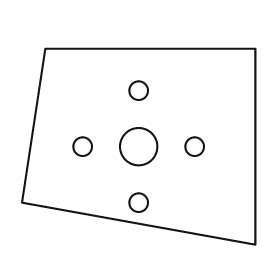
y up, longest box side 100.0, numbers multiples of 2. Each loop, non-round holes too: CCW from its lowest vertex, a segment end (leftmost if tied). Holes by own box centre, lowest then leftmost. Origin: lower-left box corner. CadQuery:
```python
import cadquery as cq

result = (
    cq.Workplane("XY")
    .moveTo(100.0, 0.0)
    .lineTo(100.0, 84.0)
    .lineTo(10.0, 84.0)
    .lineTo(0.0, 18.0)
    .close()
    .moveTo(50.0, 18.0)
    .circle(4.0)
    .moveTo(26.0, 42.0)
    .circle(4.0)
    .moveTo(50.0, 42.0)
    .circle(8.0)
    .moveTo(74.0, 42.0)
    .circle(4.0)
    .moveTo(50.0, 66.0)
    .circle(4.0)
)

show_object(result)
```